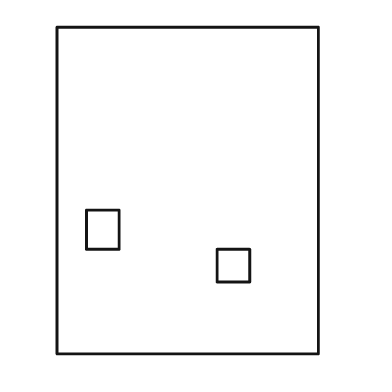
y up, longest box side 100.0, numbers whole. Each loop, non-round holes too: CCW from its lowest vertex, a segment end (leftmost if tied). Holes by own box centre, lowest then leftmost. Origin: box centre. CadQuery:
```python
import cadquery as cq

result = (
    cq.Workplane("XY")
    .moveTo(-40.0, -50.0)
    .lineTo(40.0, -50.0)
    .lineTo(40.0, 50.0)
    .lineTo(-40.0, 50.0)
    .close()
    .moveTo(9.0, -28.0)
    .lineTo(19.0, -28.0)
    .lineTo(19.0, -18.0)
    .lineTo(9.0, -18.0)
    .close()
    .moveTo(-31.0, -18.0)
    .lineTo(-21.0, -18.0)
    .lineTo(-21.0, -6.0)
    .lineTo(-31.0, -6.0)
    .close()
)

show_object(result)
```